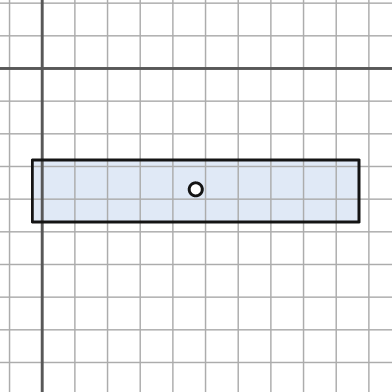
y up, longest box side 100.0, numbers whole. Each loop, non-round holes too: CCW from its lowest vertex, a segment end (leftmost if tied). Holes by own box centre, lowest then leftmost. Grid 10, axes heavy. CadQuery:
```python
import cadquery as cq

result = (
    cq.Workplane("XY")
    .moveTo(-3.0, -47.0)
    .lineTo(97.0, -47.0)
    .lineTo(97.0, -28.0)
    .lineTo(-3.0, -28.0)
    .close()
    .moveTo(47.0, -37.0)
    .circle(2.0)
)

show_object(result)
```